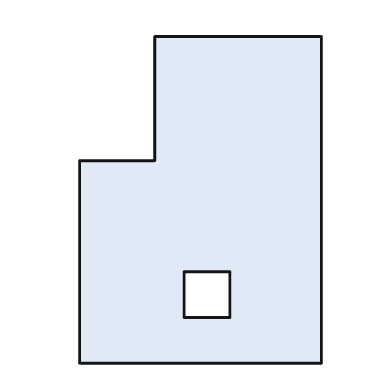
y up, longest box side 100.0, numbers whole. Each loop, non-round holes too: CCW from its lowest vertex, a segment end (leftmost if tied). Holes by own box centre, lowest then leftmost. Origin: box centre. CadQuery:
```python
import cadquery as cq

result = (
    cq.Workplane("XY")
    .moveTo(-37.0, -50.0)
    .lineTo(37.0, -50.0)
    .lineTo(37.0, 50.0)
    .lineTo(-14.0, 50.0)
    .lineTo(-14.0, 12.0)
    .lineTo(-37.0, 12.0)
    .close()
    .moveTo(-5.0, -36.0)
    .lineTo(9.0, -36.0)
    .lineTo(9.0, -22.0)
    .lineTo(-5.0, -22.0)
    .close()
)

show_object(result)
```